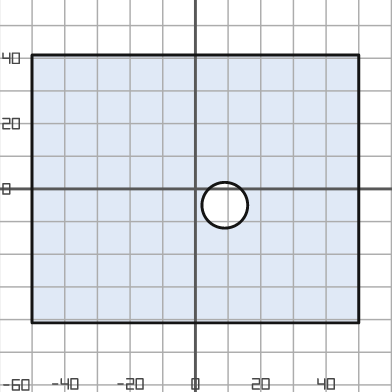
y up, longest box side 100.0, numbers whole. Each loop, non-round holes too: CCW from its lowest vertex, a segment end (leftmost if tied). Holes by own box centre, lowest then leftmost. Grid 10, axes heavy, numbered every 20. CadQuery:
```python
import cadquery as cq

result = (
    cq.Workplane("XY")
    .moveTo(-50.0, -41.0)
    .lineTo(50.0, -41.0)
    .lineTo(50.0, 41.0)
    .lineTo(-50.0, 41.0)
    .close()
    .moveTo(9.0, -5.0)
    .circle(7.0)
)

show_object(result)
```